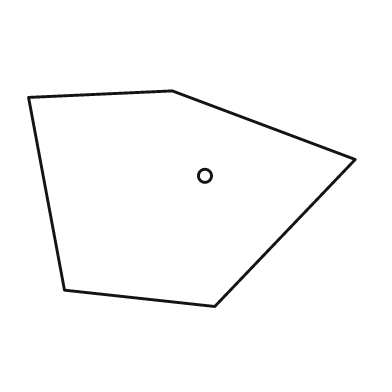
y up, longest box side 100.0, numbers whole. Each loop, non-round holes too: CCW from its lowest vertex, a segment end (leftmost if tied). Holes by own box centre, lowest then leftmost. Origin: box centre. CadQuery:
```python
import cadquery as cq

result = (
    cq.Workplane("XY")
    .moveTo(7.0, -33.0)
    .lineTo(50.0, 12.0)
    .lineTo(-6.0, 33.0)
    .lineTo(-50.0, 31.0)
    .lineTo(-39.0, -28.0)
    .close()
    .moveTo(4.0, 7.0)
    .circle(2.0)
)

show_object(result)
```